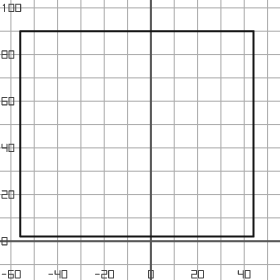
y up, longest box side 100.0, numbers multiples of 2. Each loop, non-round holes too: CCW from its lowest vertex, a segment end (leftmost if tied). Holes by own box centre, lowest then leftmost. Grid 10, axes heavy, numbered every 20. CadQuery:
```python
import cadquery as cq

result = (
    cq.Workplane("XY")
    .moveTo(-56.0, 2.0)
    .lineTo(44.0, 2.0)
    .lineTo(44.0, 90.0)
    .lineTo(-56.0, 90.0)
    .close()
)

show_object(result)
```